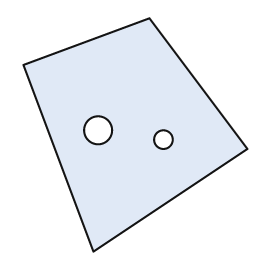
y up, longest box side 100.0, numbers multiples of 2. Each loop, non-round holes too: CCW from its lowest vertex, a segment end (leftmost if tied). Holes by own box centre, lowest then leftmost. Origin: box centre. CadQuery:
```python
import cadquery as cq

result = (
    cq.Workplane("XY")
    .moveTo(-18.0, -50.0)
    .lineTo(48.0, -6.0)
    .lineTo(6.0, 50.0)
    .lineTo(-48.0, 30.0)
    .close()
    .moveTo(12.0, -2.0)
    .circle(4.0)
    .moveTo(-16.0, 2.0)
    .circle(6.0)
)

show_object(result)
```